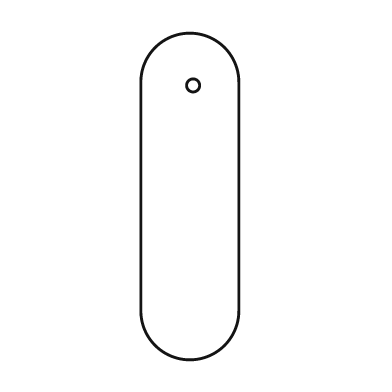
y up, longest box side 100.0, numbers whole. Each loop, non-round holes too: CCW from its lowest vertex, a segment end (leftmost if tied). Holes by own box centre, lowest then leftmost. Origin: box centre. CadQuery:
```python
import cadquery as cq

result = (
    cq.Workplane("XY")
    .moveTo(-15.0, -35.0)
    .threePointArc((0.0, -50.0), (15.0, -35.0))
    .lineTo(15.0, 35.0)
    .threePointArc((0.0, 50.0), (-15.0, 35.0))
    .close()
    .moveTo(1.0, 34.0)
    .circle(2.0)
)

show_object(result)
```